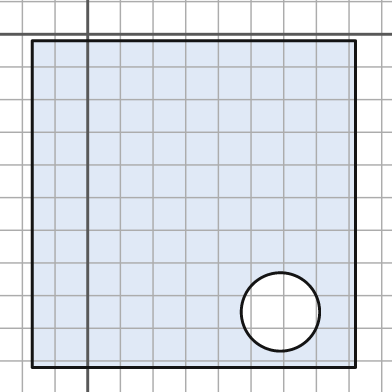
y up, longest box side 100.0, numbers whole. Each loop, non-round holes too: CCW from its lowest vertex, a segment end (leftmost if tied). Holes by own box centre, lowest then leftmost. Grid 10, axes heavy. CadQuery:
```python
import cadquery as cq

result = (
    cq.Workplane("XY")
    .moveTo(-17.0, -102.0)
    .lineTo(82.0, -102.0)
    .lineTo(82.0, -2.0)
    .lineTo(-17.0, -2.0)
    .close()
    .moveTo(59.0, -85.0)
    .circle(12.0)
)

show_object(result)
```